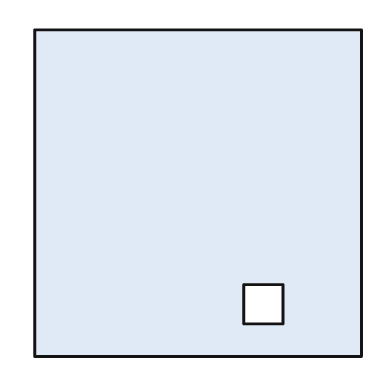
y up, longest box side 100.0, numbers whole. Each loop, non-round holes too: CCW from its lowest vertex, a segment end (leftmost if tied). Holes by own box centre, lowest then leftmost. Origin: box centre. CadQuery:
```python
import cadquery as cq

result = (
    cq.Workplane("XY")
    .moveTo(-50.0, -50.0)
    .lineTo(50.0, -50.0)
    .lineTo(50.0, 50.0)
    .lineTo(-50.0, 50.0)
    .close()
    .moveTo(14.0, -40.0)
    .lineTo(26.0, -40.0)
    .lineTo(26.0, -28.0)
    .lineTo(14.0, -28.0)
    .close()
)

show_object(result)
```